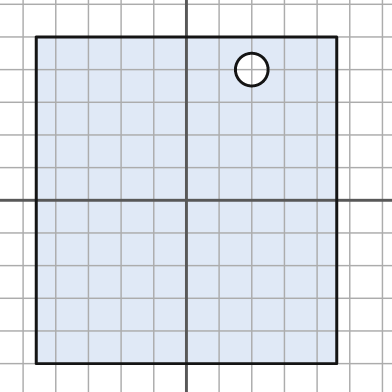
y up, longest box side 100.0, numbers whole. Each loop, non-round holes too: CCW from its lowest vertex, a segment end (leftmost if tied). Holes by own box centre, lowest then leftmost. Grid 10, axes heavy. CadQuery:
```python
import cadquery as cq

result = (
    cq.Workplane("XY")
    .moveTo(-46.0, -50.0)
    .lineTo(46.0, -50.0)
    .lineTo(46.0, 50.0)
    .lineTo(-46.0, 50.0)
    .close()
    .moveTo(20.0, 40.0)
    .circle(5.0)
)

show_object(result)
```